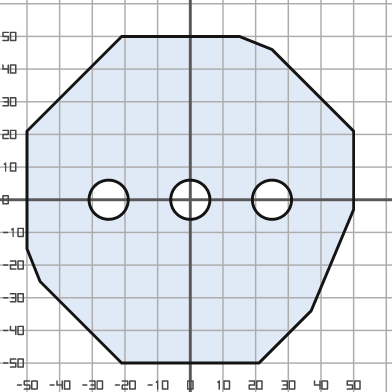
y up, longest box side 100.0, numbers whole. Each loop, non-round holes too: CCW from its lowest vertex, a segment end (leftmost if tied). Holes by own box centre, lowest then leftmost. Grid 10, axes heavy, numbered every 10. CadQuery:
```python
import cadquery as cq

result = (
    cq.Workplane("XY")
    .moveTo(-21.0, -50.0)
    .lineTo(21.0, -50.0)
    .lineTo(37.0, -34.0)
    .lineTo(50.0, -3.0)
    .lineTo(50.0, 21.0)
    .lineTo(25.0, 46.0)
    .lineTo(15.0, 50.0)
    .lineTo(-21.0, 50.0)
    .lineTo(-50.0, 21.0)
    .lineTo(-50.0, -15.0)
    .lineTo(-46.0, -25.0)
    .close()
    .moveTo(-25.0, 0.0)
    .circle(6.0)
    .moveTo(0.0, 0.0)
    .circle(6.0)
    .moveTo(25.0, 0.0)
    .circle(6.0)
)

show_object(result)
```